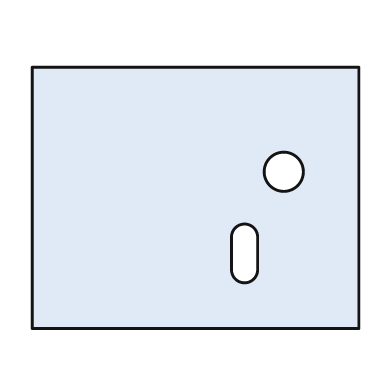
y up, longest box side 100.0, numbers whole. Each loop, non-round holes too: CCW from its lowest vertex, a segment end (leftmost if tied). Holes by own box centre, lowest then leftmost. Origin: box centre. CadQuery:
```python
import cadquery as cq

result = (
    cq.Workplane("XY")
    .moveTo(-50.0, -40.0)
    .lineTo(50.0, -40.0)
    .lineTo(50.0, 40.0)
    .lineTo(-50.0, 40.0)
    .close()
    .moveTo(11.0, -22.0)
    .threePointArc((15.0, -26.0), (19.0, -22.0))
    .lineTo(19.0, -12.0)
    .threePointArc((15.0, -8.0), (11.0, -12.0))
    .close()
    .moveTo(27.0, 8.0)
    .circle(6.0)
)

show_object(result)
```